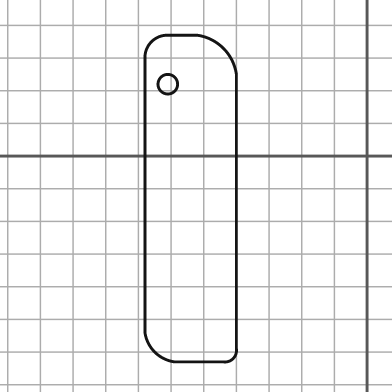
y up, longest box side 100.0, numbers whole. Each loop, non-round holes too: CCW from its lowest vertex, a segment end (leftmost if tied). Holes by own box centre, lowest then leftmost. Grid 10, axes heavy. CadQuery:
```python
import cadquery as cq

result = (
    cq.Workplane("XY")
    .moveTo(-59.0, -63.0)
    .lineTo(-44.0, -63.0)
    .threePointArc((-41.0, -62.0), (-40.0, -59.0))
    .lineTo(-40.0, 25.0)
    .threePointArc((-44.0, 33.0), (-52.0, 37.0))
    .lineTo(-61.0, 37.0)
    .threePointArc((-66.0, 35.0), (-68.0, 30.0))
    .lineTo(-68.0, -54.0)
    .threePointArc((-65.0, -60.0), (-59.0, -63.0))
    .close()
    .moveTo(-61.0, 22.0)
    .circle(3.0)
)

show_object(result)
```